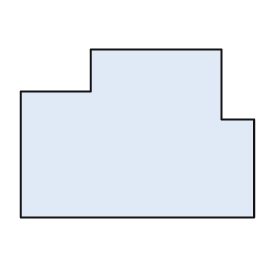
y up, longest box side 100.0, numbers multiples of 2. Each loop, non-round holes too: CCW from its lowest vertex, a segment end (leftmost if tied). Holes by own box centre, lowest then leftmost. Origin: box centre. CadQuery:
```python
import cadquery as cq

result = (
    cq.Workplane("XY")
    .moveTo(-50.0, -36.0)
    .lineTo(50.0, -36.0)
    .lineTo(50.0, 6.0)
    .lineTo(36.0, 6.0)
    .lineTo(36.0, 36.0)
    .lineTo(-20.0, 36.0)
    .lineTo(-20.0, 18.0)
    .lineTo(-50.0, 18.0)
    .close()
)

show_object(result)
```